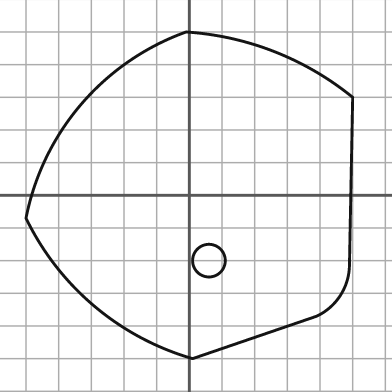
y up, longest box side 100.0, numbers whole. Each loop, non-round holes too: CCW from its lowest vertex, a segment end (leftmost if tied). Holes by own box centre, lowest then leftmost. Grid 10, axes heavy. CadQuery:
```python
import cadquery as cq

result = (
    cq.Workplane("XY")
    .moveTo(1.0, -50.0)
    .lineTo(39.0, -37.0)
    .threePointArc((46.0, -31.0), (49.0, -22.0))
    .lineTo(50.0, 30.0)
    .threePointArc((26.0, 44.0), (-1.0, 50.0))
    .threePointArc((-33.0, 28.0), (-50.0, -7.0))
    .threePointArc((-29.0, -34.0), (1.0, -50.0))
    .close()
    .moveTo(6.0, -20.0)
    .circle(5.0)
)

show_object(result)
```